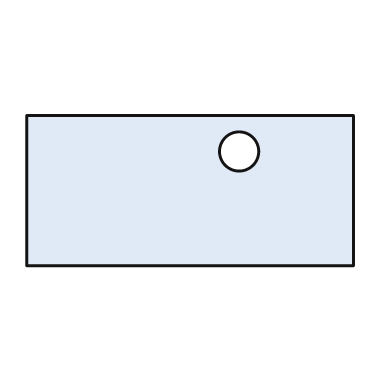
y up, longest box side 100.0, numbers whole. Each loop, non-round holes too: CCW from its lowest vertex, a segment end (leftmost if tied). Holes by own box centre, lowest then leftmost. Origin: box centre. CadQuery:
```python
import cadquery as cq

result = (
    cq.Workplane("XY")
    .moveTo(-50.0, -23.0)
    .lineTo(50.0, -23.0)
    .lineTo(50.0, 23.0)
    .lineTo(-50.0, 23.0)
    .close()
    .moveTo(15.0, 12.0)
    .circle(6.0)
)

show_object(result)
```